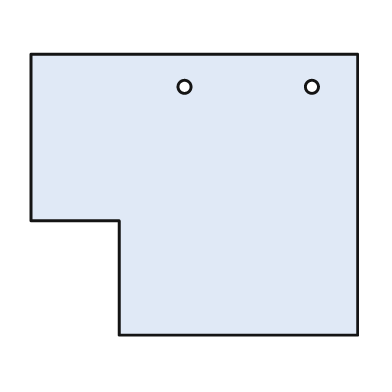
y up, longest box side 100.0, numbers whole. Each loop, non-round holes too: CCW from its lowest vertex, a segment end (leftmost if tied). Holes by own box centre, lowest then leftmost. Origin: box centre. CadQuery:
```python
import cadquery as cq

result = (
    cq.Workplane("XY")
    .moveTo(-23.0, -43.0)
    .lineTo(50.0, -43.0)
    .lineTo(50.0, 43.0)
    .lineTo(-50.0, 43.0)
    .lineTo(-50.0, -8.0)
    .lineTo(-23.0, -8.0)
    .close()
    .moveTo(-3.0, 33.0)
    .circle(2.0)
    .moveTo(36.0, 33.0)
    .circle(2.0)
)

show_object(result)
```